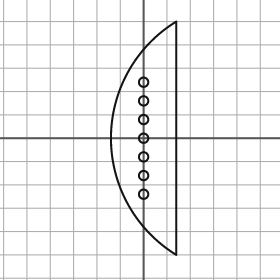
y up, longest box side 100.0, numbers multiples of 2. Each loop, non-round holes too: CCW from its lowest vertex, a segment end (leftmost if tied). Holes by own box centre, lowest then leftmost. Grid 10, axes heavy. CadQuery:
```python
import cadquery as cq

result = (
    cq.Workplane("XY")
    .moveTo(14.0, -50.0)
    .lineTo(14.0, 50.0)
    .threePointArc((-14.0, 0.0), (14.0, -50.0))
    .close()
    .moveTo(0.0, -24.0)
    .circle(2.0)
    .moveTo(0.0, -16.0)
    .circle(2.0)
    .moveTo(0.0, -8.0)
    .circle(2.0)
    .moveTo(0.0, 0.0)
    .circle(2.0)
    .moveTo(0.0, 8.0)
    .circle(2.0)
    .moveTo(0.0, 16.0)
    .circle(2.0)
    .moveTo(0.0, 24.0)
    .circle(2.0)
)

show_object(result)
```